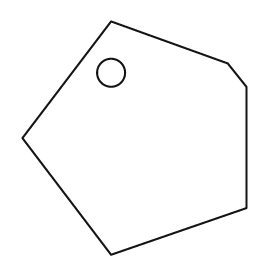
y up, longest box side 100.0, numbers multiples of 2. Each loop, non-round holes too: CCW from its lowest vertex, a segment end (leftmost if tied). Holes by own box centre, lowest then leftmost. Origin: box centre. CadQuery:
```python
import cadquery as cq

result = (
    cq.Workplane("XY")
    .moveTo(-10.0, -50.0)
    .lineTo(48.0, -30.0)
    .lineTo(48.0, 22.0)
    .lineTo(40.0, 32.0)
    .lineTo(-10.0, 50.0)
    .lineTo(-48.0, 0.0)
    .close()
    .moveTo(-10.0, 28.0)
    .circle(6.0)
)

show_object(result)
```